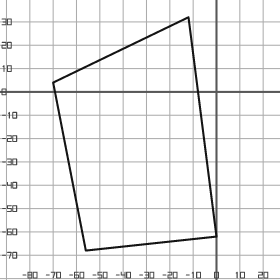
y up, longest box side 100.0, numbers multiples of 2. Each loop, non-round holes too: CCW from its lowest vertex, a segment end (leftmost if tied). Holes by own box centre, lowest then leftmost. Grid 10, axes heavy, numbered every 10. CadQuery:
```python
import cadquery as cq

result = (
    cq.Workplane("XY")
    .moveTo(-56.0, -68.0)
    .lineTo(0.0, -62.0)
    .lineTo(-12.0, 32.0)
    .lineTo(-70.0, 4.0)
    .close()
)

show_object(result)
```